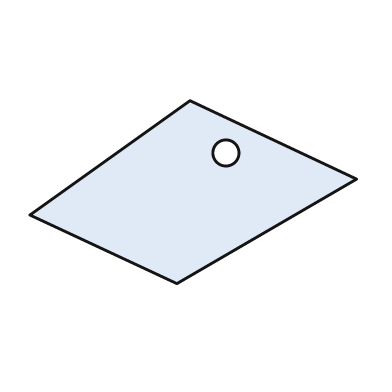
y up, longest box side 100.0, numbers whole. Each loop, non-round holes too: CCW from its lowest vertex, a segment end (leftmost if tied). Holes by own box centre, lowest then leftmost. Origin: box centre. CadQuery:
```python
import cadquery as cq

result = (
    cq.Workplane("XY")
    .moveTo(-5.0, -28.0)
    .lineTo(50.0, 4.0)
    .lineTo(-1.0, 28.0)
    .lineTo(-50.0, -7.0)
    .close()
    .moveTo(10.0, 12.0)
    .circle(4.0)
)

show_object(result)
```